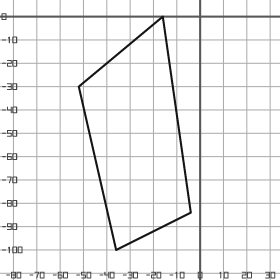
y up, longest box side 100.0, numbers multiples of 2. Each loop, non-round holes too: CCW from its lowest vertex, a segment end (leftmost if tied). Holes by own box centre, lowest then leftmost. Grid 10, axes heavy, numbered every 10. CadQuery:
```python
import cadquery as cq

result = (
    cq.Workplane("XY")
    .moveTo(-36.0, -100.0)
    .lineTo(-4.0, -84.0)
    .lineTo(-16.0, 0.0)
    .lineTo(-52.0, -30.0)
    .close()
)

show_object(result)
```